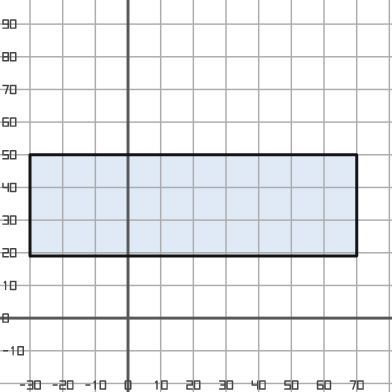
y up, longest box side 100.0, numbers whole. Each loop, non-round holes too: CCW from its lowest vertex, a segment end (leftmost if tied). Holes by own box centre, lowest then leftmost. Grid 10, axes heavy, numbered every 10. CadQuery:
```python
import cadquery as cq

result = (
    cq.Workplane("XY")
    .moveTo(-30.0, 19.0)
    .lineTo(70.0, 19.0)
    .lineTo(70.0, 50.0)
    .lineTo(-30.0, 50.0)
    .close()
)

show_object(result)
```